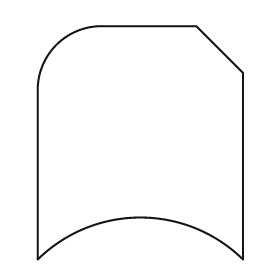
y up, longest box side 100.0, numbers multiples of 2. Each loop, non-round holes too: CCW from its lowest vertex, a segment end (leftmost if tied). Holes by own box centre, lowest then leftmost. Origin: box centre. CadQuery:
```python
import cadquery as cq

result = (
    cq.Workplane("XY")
    .moveTo(-44.0, -50.0)
    .threePointArc((0.0, -32.0), (44.0, -50.0))
    .lineTo(44.0, 30.0)
    .lineTo(24.0, 50.0)
    .lineTo(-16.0, 50.0)
    .threePointArc((-36.0, 42.0), (-44.0, 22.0))
    .close()
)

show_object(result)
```